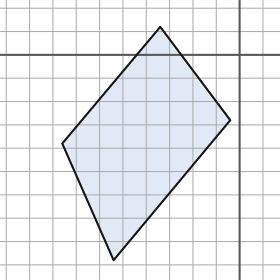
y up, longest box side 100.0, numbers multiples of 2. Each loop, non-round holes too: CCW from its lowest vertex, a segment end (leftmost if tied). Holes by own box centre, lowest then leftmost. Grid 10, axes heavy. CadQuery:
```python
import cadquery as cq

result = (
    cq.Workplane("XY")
    .moveTo(-54.0, -88.0)
    .lineTo(-4.0, -28.0)
    .lineTo(-34.0, 12.0)
    .lineTo(-76.0, -38.0)
    .close()
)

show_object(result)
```